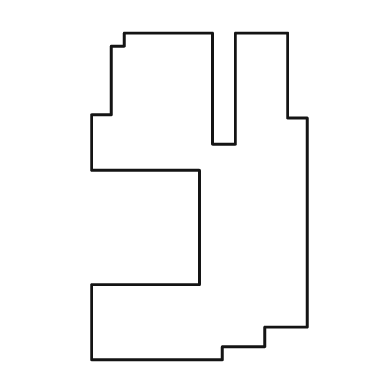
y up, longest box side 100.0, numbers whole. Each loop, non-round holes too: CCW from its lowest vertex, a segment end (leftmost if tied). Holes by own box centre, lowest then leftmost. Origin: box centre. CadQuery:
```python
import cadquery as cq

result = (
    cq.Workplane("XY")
    .moveTo(-33.0, -50.0)
    .lineTo(7.0, -50.0)
    .lineTo(7.0, -46.0)
    .lineTo(20.0, -46.0)
    .lineTo(20.0, -40.0)
    .lineTo(33.0, -40.0)
    .lineTo(33.0, 24.0)
    .lineTo(27.0, 24.0)
    .lineTo(27.0, 50.0)
    .lineTo(11.0, 50.0)
    .lineTo(11.0, 16.0)
    .lineTo(4.0, 16.0)
    .lineTo(4.0, 50.0)
    .lineTo(-23.0, 50.0)
    .lineTo(-23.0, 46.0)
    .lineTo(-27.0, 46.0)
    .lineTo(-27.0, 25.0)
    .lineTo(-33.0, 25.0)
    .lineTo(-33.0, 8.0)
    .lineTo(0.0, 8.0)
    .lineTo(0.0, -27.0)
    .lineTo(-33.0, -27.0)
    .close()
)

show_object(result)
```